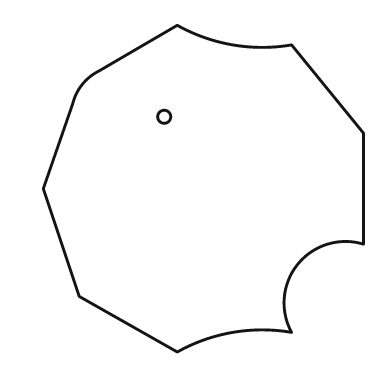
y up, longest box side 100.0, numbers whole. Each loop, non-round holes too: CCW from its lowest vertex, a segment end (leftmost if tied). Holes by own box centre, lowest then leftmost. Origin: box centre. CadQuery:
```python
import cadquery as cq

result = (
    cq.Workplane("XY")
    .moveTo(-8.0, -50.0)
    .threePointArc((9.0, -44.0), (27.0, -44.0))
    .threePointArc((29.0, -23.0), (49.0, -17.0))
    .lineTo(49.0, 17.0)
    .lineTo(27.0, 44.0)
    .threePointArc((9.0, 44.0), (-8.0, 50.0))
    .lineTo(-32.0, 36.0)
    .threePointArc((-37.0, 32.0), (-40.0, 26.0))
    .lineTo(-49.0, 0.0)
    .lineTo(-38.0, -33.0)
    .close()
    .moveTo(-12.0, 22.0)
    .circle(2.0)
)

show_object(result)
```